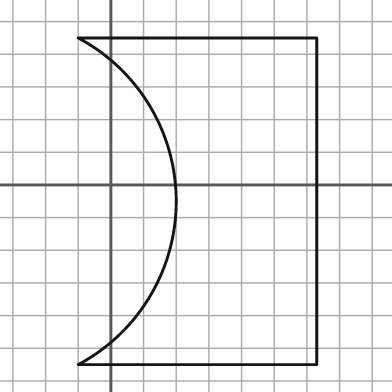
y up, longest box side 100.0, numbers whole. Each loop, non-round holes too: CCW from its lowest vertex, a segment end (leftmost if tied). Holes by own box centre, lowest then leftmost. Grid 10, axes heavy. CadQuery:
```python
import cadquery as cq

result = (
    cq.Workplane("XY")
    .moveTo(-10.0, -55.0)
    .lineTo(63.0, -55.0)
    .lineTo(63.0, 45.0)
    .lineTo(-10.0, 45.0)
    .threePointArc((20.0, -5.0), (-10.0, -55.0))
    .close()
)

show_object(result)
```